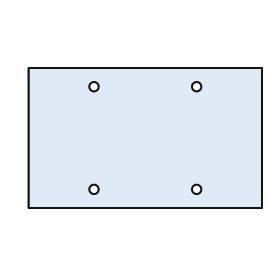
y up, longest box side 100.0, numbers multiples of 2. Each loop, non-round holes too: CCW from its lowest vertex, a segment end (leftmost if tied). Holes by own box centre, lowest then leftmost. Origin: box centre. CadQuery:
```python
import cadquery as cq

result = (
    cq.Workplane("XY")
    .moveTo(-50.0, -30.0)
    .lineTo(50.0, -30.0)
    .lineTo(50.0, 30.0)
    .lineTo(-50.0, 30.0)
    .close()
    .moveTo(-22.0, -22.0)
    .circle(2.0)
    .moveTo(22.0, -22.0)
    .circle(2.0)
    .moveTo(-22.0, 22.0)
    .circle(2.0)
    .moveTo(22.0, 22.0)
    .circle(2.0)
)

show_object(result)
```